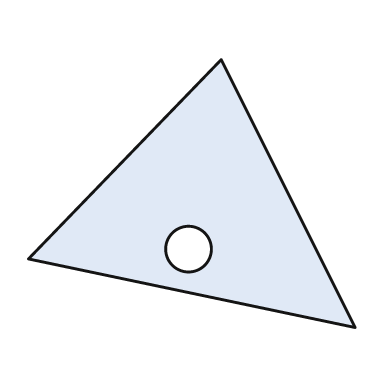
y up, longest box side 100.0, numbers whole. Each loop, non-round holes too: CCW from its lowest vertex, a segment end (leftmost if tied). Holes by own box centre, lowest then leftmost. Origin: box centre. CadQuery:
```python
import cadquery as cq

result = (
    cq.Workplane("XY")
    .moveTo(50.0, -41.0)
    .lineTo(9.0, 41.0)
    .lineTo(-50.0, -20.0)
    .close()
    .moveTo(-1.0, -17.0)
    .circle(7.0)
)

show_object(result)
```